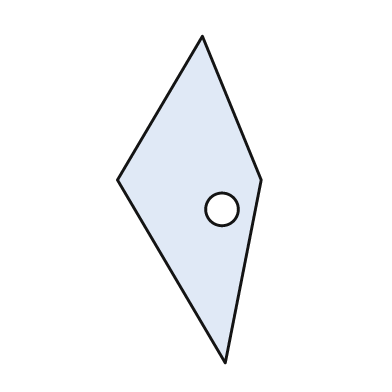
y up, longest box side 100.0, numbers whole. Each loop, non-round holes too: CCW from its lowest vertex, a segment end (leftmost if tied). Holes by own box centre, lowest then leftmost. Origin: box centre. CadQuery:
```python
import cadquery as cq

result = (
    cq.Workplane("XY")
    .moveTo(11.0, -50.0)
    .lineTo(22.0, 6.0)
    .lineTo(4.0, 50.0)
    .lineTo(-22.0, 6.0)
    .close()
    .moveTo(10.0, -3.0)
    .circle(5.0)
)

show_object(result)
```